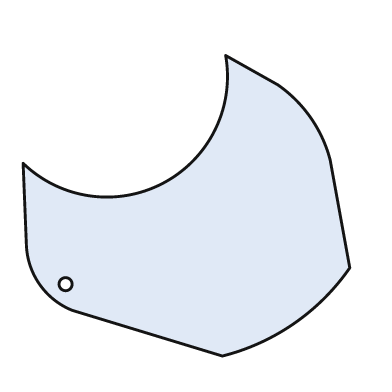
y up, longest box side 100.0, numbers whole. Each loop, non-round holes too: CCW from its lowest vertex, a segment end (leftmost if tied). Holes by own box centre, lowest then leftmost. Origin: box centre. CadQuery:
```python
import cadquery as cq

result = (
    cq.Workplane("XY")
    .moveTo(11.0, -46.0)
    .threePointArc((33.0, -36.0), (50.0, -19.0))
    .lineTo(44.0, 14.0)
    .threePointArc((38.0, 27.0), (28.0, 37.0))
    .lineTo(12.0, 46.0)
    .threePointArc((-7.0, 7.0), (-50.0, 13.0))
    .lineTo(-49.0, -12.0)
    .threePointArc((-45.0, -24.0), (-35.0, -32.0))
    .close()
    .moveTo(-37.0, -24.0)
    .circle(2.0)
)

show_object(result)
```